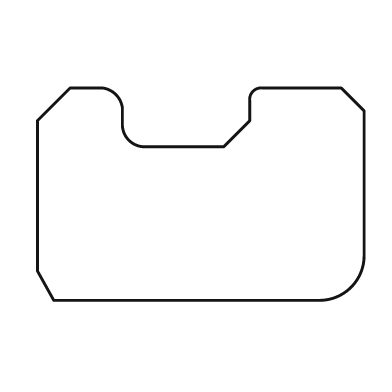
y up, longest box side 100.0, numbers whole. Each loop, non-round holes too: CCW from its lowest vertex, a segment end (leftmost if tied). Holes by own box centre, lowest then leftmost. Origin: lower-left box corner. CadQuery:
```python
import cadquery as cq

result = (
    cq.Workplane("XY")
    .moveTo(5.0, 0.0)
    .lineTo(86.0, 0.0)
    .threePointArc((96.0, 4.0), (100.0, 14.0))
    .lineTo(100.0, 58.0)
    .lineTo(93.0, 65.0)
    .lineTo(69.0, 65.0)
    .threePointArc((66.0, 64.0), (65.0, 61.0))
    .lineTo(65.0, 55.0)
    .lineTo(57.0, 47.0)
    .lineTo(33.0, 47.0)
    .threePointArc((28.0, 49.0), (26.0, 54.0))
    .lineTo(26.0, 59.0)
    .threePointArc((24.0, 63.0), (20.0, 65.0))
    .lineTo(10.0, 65.0)
    .lineTo(0.0, 55.0)
    .lineTo(0.0, 9.0)
    .close()
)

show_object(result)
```